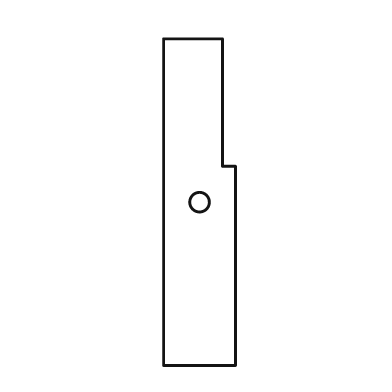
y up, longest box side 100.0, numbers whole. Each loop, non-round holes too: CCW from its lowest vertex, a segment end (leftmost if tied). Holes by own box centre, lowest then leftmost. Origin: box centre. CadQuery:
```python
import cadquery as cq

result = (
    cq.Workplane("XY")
    .moveTo(-11.0, -50.0)
    .lineTo(11.0, -50.0)
    .lineTo(11.0, 11.0)
    .lineTo(7.0, 11.0)
    .lineTo(7.0, 50.0)
    .lineTo(-11.0, 50.0)
    .close()
    .moveTo(0.0, 0.0)
    .circle(3.0)
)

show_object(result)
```